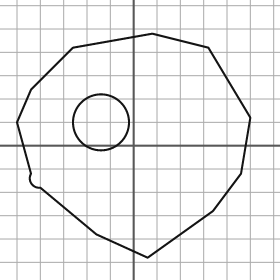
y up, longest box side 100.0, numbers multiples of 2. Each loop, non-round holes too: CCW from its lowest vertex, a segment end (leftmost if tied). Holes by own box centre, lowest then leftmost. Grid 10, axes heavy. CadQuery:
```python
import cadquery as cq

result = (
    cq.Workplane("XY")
    .moveTo(6.0, -48.0)
    .lineTo(34.0, -28.0)
    .lineTo(46.0, -12.0)
    .lineTo(50.0, 12.0)
    .lineTo(32.0, 42.0)
    .lineTo(8.0, 48.0)
    .lineTo(-26.0, 42.0)
    .lineTo(-44.0, 24.0)
    .lineTo(-50.0, 10.0)
    .lineTo(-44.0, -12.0)
    .threePointArc((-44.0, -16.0), (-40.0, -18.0))
    .lineTo(-16.0, -38.0)
    .close()
    .moveTo(-14.0, 10.0)
    .circle(12.0)
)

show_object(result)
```